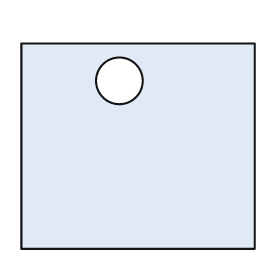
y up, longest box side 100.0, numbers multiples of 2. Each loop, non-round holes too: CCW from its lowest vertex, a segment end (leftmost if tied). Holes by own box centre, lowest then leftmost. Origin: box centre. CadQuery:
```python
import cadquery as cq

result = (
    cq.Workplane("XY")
    .moveTo(-50.0, -44.0)
    .lineTo(50.0, -44.0)
    .lineTo(50.0, 44.0)
    .lineTo(-50.0, 44.0)
    .close()
    .moveTo(-8.0, 28.0)
    .circle(10.0)
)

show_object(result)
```